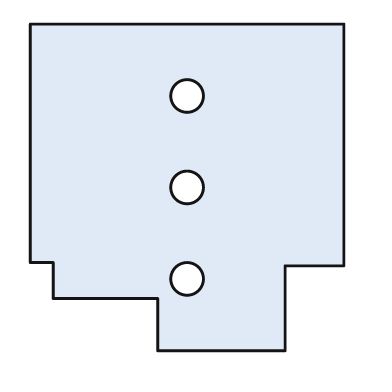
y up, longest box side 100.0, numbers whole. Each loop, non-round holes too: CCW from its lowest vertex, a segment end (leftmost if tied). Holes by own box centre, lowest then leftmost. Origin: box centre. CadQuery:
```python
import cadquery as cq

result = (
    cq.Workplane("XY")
    .moveTo(-9.0, -50.0)
    .lineTo(30.0, -50.0)
    .lineTo(30.0, -24.0)
    .lineTo(48.0, -24.0)
    .lineTo(48.0, 50.0)
    .lineTo(-48.0, 50.0)
    .lineTo(-48.0, -23.0)
    .lineTo(-41.0, -23.0)
    .lineTo(-41.0, -34.0)
    .lineTo(-9.0, -34.0)
    .close()
    .moveTo(0.0, -28.0)
    .circle(5.0)
    .moveTo(0.0, 0.0)
    .circle(5.0)
    .moveTo(0.0, 28.0)
    .circle(5.0)
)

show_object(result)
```